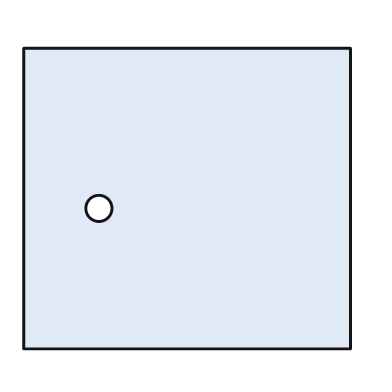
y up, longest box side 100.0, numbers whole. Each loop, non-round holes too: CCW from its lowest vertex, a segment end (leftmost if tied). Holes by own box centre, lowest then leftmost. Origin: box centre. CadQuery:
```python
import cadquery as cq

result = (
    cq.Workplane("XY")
    .moveTo(-50.0, -46.0)
    .lineTo(50.0, -46.0)
    .lineTo(50.0, 46.0)
    .lineTo(-50.0, 46.0)
    .close()
    .moveTo(-27.0, -3.0)
    .circle(4.0)
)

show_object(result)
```